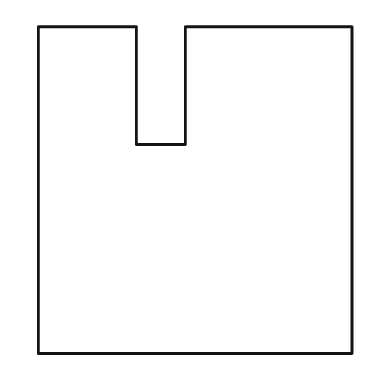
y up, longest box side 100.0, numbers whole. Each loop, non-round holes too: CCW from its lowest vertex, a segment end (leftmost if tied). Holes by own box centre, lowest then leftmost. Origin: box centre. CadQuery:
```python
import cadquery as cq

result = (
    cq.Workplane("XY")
    .moveTo(-48.0, -50.0)
    .lineTo(48.0, -50.0)
    .lineTo(48.0, 50.0)
    .lineTo(-3.0, 50.0)
    .lineTo(-3.0, 14.0)
    .lineTo(-18.0, 14.0)
    .lineTo(-18.0, 50.0)
    .lineTo(-48.0, 50.0)
    .close()
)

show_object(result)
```